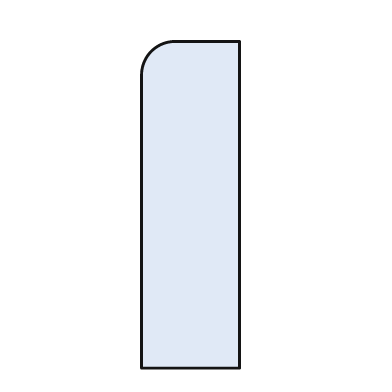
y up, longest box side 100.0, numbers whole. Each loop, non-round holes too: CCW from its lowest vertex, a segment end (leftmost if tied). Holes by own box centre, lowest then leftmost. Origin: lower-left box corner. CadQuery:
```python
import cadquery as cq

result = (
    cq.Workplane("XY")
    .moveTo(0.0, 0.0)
    .lineTo(30.0, 0.0)
    .lineTo(30.0, 100.0)
    .lineTo(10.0, 100.0)
    .threePointArc((3.0, 97.0), (0.0, 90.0))
    .close()
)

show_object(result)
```